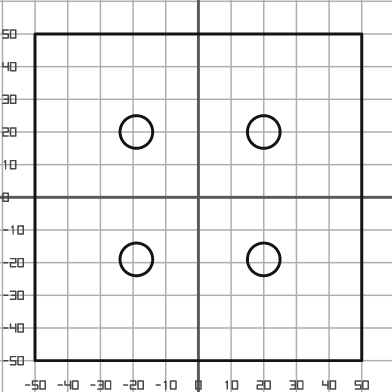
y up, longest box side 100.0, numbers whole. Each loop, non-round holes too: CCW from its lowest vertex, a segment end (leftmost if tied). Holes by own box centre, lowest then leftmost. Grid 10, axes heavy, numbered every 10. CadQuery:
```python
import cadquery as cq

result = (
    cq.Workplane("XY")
    .moveTo(-50.0, -50.0)
    .lineTo(50.0, -50.0)
    .lineTo(50.0, 50.0)
    .lineTo(-50.0, 50.0)
    .close()
    .moveTo(-19.0, -19.0)
    .circle(5.0)
    .moveTo(20.0, -19.0)
    .circle(5.0)
    .moveTo(-19.0, 20.0)
    .circle(5.0)
    .moveTo(20.0, 20.0)
    .circle(5.0)
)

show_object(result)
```